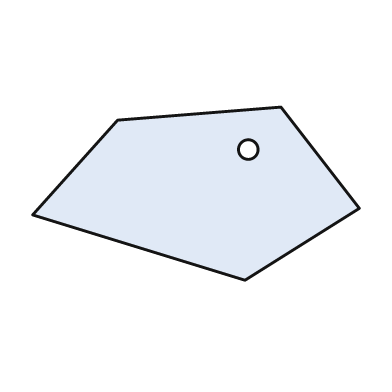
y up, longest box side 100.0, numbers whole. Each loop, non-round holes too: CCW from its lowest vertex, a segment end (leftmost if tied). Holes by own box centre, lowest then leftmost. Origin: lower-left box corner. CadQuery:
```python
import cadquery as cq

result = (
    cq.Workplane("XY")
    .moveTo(65.0, 0.0)
    .lineTo(100.0, 22.0)
    .lineTo(76.0, 53.0)
    .lineTo(26.0, 49.0)
    .lineTo(0.0, 20.0)
    .close()
    .moveTo(66.0, 40.0)
    .circle(3.0)
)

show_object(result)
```